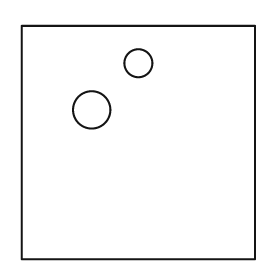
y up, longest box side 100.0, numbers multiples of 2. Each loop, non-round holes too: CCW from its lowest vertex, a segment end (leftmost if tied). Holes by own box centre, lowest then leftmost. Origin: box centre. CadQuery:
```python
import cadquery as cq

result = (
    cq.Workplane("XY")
    .moveTo(-50.0, -50.0)
    .lineTo(50.0, -50.0)
    .lineTo(50.0, 50.0)
    .lineTo(-50.0, 50.0)
    .close()
    .moveTo(-20.0, 14.0)
    .circle(8.0)
    .moveTo(0.0, 34.0)
    .circle(6.0)
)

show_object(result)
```